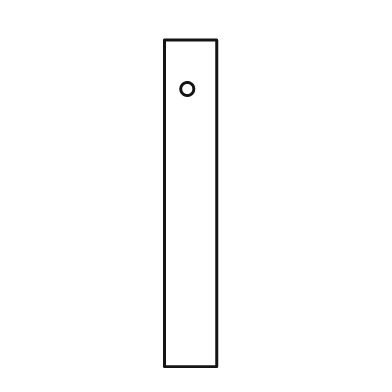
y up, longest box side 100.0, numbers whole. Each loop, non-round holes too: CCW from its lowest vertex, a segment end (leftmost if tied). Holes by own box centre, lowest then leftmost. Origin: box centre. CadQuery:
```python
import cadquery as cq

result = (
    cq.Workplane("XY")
    .moveTo(-8.0, -50.0)
    .lineTo(8.0, -50.0)
    .lineTo(8.0, 50.0)
    .lineTo(-8.0, 50.0)
    .close()
    .moveTo(-1.0, 35.0)
    .circle(2.0)
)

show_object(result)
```